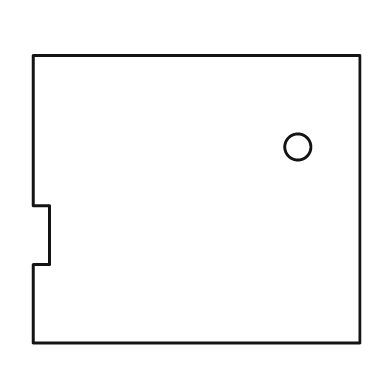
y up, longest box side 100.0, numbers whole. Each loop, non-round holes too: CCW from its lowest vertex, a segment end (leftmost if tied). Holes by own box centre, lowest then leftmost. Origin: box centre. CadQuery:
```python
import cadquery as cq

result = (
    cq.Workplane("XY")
    .moveTo(-50.0, -44.0)
    .lineTo(50.0, -44.0)
    .lineTo(50.0, 44.0)
    .lineTo(-50.0, 44.0)
    .lineTo(-50.0, -2.0)
    .lineTo(-45.0, -2.0)
    .lineTo(-45.0, -20.0)
    .lineTo(-50.0, -20.0)
    .close()
    .moveTo(31.0, 16.0)
    .circle(4.0)
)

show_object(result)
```